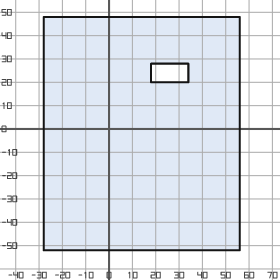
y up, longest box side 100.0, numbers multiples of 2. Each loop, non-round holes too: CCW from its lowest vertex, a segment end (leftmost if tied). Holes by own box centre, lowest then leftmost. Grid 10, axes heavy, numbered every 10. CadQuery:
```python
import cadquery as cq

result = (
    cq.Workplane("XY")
    .moveTo(-28.0, -52.0)
    .lineTo(56.0, -52.0)
    .lineTo(56.0, 48.0)
    .lineTo(-28.0, 48.0)
    .close()
    .moveTo(18.0, 20.0)
    .lineTo(34.0, 20.0)
    .lineTo(34.0, 28.0)
    .lineTo(18.0, 28.0)
    .close()
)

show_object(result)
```